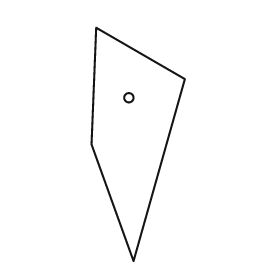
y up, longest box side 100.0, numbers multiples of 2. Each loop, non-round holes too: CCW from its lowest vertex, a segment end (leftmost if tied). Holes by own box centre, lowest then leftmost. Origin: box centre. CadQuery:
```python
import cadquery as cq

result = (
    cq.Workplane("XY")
    .moveTo(-2.0, -50.0)
    .lineTo(20.0, 28.0)
    .lineTo(-18.0, 50.0)
    .lineTo(-20.0, 0.0)
    .close()
    .moveTo(-4.0, 20.0)
    .circle(2.0)
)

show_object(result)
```